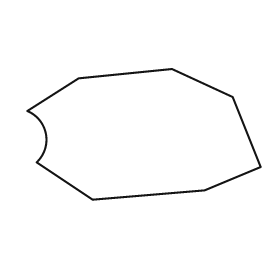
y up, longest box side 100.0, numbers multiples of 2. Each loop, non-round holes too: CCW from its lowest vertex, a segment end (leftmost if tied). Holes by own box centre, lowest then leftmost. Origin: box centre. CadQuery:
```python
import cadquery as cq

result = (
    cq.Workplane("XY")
    .moveTo(-22.0, -28.0)
    .lineTo(26.0, -24.0)
    .lineTo(50.0, -14.0)
    .lineTo(38.0, 16.0)
    .lineTo(12.0, 28.0)
    .lineTo(-28.0, 24.0)
    .lineTo(-50.0, 10.0)
    .threePointArc((-42.0, 0.0), (-46.0, -12.0))
    .close()
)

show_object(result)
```